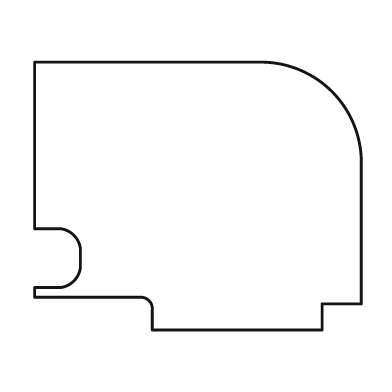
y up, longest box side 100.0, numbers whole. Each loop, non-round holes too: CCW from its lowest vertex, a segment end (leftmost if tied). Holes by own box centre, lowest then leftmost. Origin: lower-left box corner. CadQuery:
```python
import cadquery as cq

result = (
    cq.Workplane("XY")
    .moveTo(36.0, 0.0)
    .lineTo(88.0, 0.0)
    .lineTo(88.0, 8.0)
    .lineTo(100.0, 8.0)
    .lineTo(100.0, 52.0)
    .threePointArc((91.0, 73.0), (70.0, 82.0))
    .lineTo(0.0, 82.0)
    .lineTo(0.0, 31.0)
    .lineTo(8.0, 31.0)
    .threePointArc((12.0, 29.0), (14.0, 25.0))
    .lineTo(14.0, 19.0)
    .threePointArc((12.0, 15.0), (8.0, 13.0))
    .lineTo(0.0, 13.0)
    .lineTo(0.0, 10.0)
    .lineTo(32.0, 10.0)
    .threePointArc((35.0, 9.0), (36.0, 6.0))
    .close()
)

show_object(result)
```